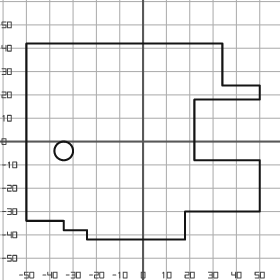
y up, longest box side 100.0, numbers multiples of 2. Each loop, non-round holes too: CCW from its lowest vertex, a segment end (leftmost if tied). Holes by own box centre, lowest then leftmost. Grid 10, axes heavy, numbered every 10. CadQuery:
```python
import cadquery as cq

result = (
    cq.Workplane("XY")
    .moveTo(-24.0, -42.0)
    .lineTo(18.0, -42.0)
    .lineTo(18.0, -30.0)
    .lineTo(50.0, -30.0)
    .lineTo(50.0, -8.0)
    .lineTo(22.0, -8.0)
    .lineTo(22.0, 18.0)
    .lineTo(50.0, 18.0)
    .lineTo(50.0, 24.0)
    .lineTo(34.0, 24.0)
    .lineTo(34.0, 42.0)
    .lineTo(-50.0, 42.0)
    .lineTo(-50.0, -34.0)
    .lineTo(-34.0, -34.0)
    .lineTo(-34.0, -38.0)
    .lineTo(-24.0, -38.0)
    .close()
    .moveTo(-34.0, -4.0)
    .circle(4.0)
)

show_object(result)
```